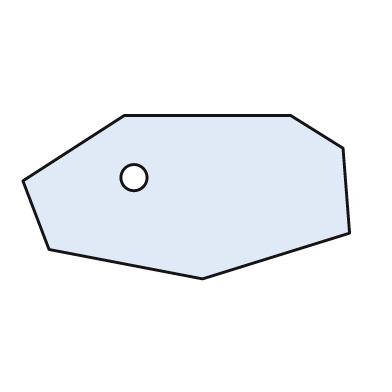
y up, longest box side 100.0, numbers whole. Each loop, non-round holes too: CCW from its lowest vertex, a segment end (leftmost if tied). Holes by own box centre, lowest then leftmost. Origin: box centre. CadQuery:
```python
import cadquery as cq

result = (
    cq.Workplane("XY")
    .moveTo(5.0, -25.0)
    .lineTo(50.0, -11.0)
    .lineTo(48.0, 15.0)
    .lineTo(32.0, 25.0)
    .lineTo(-19.0, 25.0)
    .lineTo(-50.0, 5.0)
    .lineTo(-42.0, -16.0)
    .close()
    .moveTo(-16.0, 6.0)
    .circle(4.0)
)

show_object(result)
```